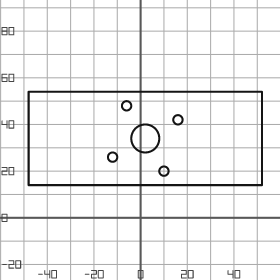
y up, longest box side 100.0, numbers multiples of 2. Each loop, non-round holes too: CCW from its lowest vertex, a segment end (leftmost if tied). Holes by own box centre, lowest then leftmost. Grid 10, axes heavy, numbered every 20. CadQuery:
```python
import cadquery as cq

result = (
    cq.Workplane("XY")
    .moveTo(-48.0, 14.0)
    .lineTo(52.0, 14.0)
    .lineTo(52.0, 54.0)
    .lineTo(-48.0, 54.0)
    .close()
    .moveTo(10.0, 20.0)
    .circle(2.0)
    .moveTo(-12.0, 26.0)
    .circle(2.0)
    .moveTo(2.0, 34.0)
    .circle(6.0)
    .moveTo(16.0, 42.0)
    .circle(2.0)
    .moveTo(-6.0, 48.0)
    .circle(2.0)
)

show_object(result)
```